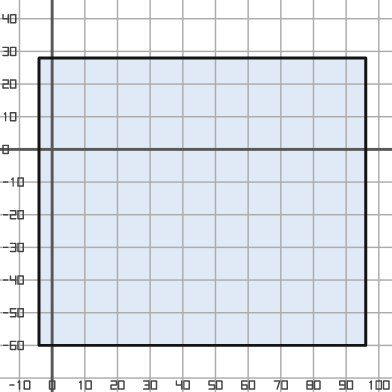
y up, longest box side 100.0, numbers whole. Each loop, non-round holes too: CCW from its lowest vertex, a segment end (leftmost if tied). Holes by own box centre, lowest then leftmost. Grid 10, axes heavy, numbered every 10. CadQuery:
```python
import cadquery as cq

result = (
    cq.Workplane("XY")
    .moveTo(-4.0, -60.0)
    .lineTo(96.0, -60.0)
    .lineTo(96.0, 28.0)
    .lineTo(-4.0, 28.0)
    .close()
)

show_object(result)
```